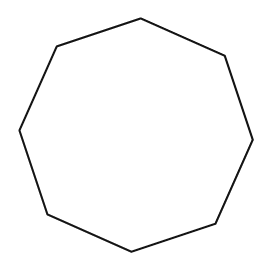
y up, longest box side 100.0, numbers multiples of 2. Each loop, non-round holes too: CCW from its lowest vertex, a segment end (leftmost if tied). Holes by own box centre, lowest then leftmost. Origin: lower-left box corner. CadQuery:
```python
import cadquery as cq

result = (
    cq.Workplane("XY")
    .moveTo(48.0, 0.0)
    .lineTo(84.0, 12.0)
    .lineTo(100.0, 48.0)
    .lineTo(88.0, 84.0)
    .lineTo(52.0, 100.0)
    .lineTo(16.0, 88.0)
    .lineTo(0.0, 52.0)
    .lineTo(12.0, 16.0)
    .close()
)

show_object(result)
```